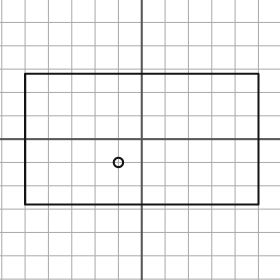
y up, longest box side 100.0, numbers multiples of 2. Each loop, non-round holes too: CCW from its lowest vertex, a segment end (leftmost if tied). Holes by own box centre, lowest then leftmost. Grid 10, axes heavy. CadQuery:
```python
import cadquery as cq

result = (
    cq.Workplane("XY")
    .moveTo(-50.0, -28.0)
    .lineTo(50.0, -28.0)
    .lineTo(50.0, 28.0)
    .lineTo(-50.0, 28.0)
    .close()
    .moveTo(-10.0, -10.0)
    .circle(2.0)
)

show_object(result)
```